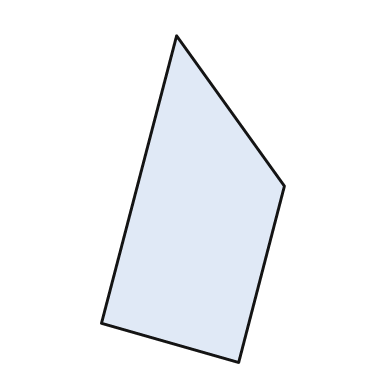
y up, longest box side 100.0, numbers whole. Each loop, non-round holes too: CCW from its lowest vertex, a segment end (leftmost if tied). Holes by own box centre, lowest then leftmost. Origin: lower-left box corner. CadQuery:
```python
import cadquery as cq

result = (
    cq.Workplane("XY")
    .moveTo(42.0, 0.0)
    .lineTo(56.0, 54.0)
    .lineTo(23.0, 100.0)
    .lineTo(0.0, 12.0)
    .close()
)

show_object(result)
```